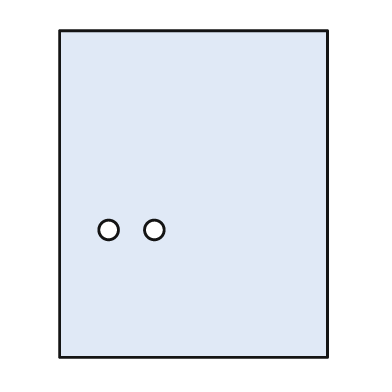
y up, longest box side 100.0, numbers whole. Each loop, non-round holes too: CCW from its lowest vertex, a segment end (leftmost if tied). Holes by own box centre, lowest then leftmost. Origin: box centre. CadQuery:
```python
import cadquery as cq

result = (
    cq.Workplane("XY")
    .moveTo(-41.0, -50.0)
    .lineTo(41.0, -50.0)
    .lineTo(41.0, 50.0)
    .lineTo(-41.0, 50.0)
    .close()
    .moveTo(-26.0, -11.0)
    .circle(3.0)
    .moveTo(-12.0, -11.0)
    .circle(3.0)
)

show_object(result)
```